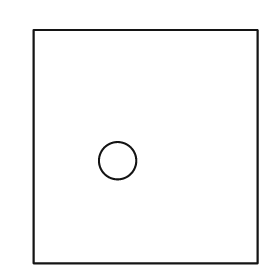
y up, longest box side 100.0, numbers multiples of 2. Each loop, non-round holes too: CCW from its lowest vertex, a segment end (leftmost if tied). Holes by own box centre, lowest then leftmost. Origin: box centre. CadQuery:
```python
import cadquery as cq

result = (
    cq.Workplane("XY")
    .moveTo(-48.0, -50.0)
    .lineTo(48.0, -50.0)
    .lineTo(48.0, 50.0)
    .lineTo(-48.0, 50.0)
    .close()
    .moveTo(-12.0, -6.0)
    .circle(8.0)
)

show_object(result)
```